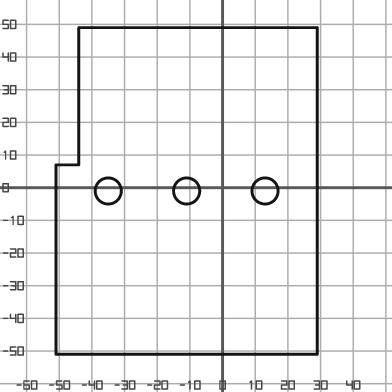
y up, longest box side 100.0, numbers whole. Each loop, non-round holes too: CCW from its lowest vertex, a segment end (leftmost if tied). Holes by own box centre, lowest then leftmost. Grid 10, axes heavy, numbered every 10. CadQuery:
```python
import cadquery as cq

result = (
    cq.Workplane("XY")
    .moveTo(-51.0, -51.0)
    .lineTo(29.0, -51.0)
    .lineTo(29.0, 49.0)
    .lineTo(-44.0, 49.0)
    .lineTo(-44.0, 7.0)
    .lineTo(-51.0, 7.0)
    .close()
    .moveTo(-35.0, -1.0)
    .circle(4.0)
    .moveTo(-11.0, -1.0)
    .circle(4.0)
    .moveTo(13.0, -1.0)
    .circle(4.0)
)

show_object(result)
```